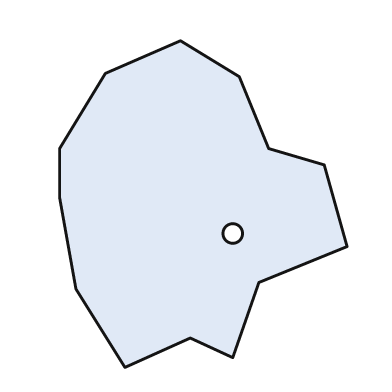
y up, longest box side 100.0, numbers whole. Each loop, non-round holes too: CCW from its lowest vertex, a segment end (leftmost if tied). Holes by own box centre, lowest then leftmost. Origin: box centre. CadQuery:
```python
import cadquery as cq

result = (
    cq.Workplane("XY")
    .moveTo(-24.0, -50.0)
    .lineTo(-4.0, -41.0)
    .lineTo(9.0, -47.0)
    .lineTo(17.0, -24.0)
    .lineTo(44.0, -13.0)
    .lineTo(37.0, 12.0)
    .lineTo(20.0, 17.0)
    .lineTo(11.0, 39.0)
    .lineTo(-7.0, 50.0)
    .lineTo(-30.0, 40.0)
    .lineTo(-44.0, 17.0)
    .lineTo(-44.0, 2.0)
    .lineTo(-39.0, -26.0)
    .close()
    .moveTo(9.0, -9.0)
    .circle(3.0)
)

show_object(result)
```